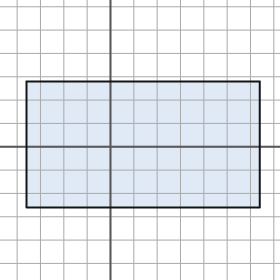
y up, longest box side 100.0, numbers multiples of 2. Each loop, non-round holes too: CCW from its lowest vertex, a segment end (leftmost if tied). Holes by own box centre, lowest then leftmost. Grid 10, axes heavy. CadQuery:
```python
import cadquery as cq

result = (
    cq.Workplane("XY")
    .moveTo(-36.0, -26.0)
    .lineTo(64.0, -26.0)
    .lineTo(64.0, 28.0)
    .lineTo(-36.0, 28.0)
    .close()
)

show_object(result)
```